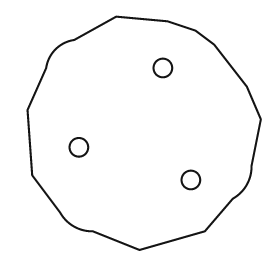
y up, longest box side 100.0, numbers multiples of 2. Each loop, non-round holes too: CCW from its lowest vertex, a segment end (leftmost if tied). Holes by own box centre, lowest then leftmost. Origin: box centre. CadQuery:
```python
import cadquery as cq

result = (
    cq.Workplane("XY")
    .moveTo(-2.0, -50.0)
    .lineTo(26.0, -42.0)
    .lineTo(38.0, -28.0)
    .threePointArc((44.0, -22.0), (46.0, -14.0))
    .lineTo(50.0, 6.0)
    .lineTo(44.0, 20.0)
    .lineTo(30.0, 38.0)
    .lineTo(22.0, 44.0)
    .lineTo(10.0, 48.0)
    .lineTo(-12.0, 50.0)
    .lineTo(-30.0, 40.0)
    .threePointArc((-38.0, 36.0), (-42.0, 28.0))
    .lineTo(-50.0, 10.0)
    .lineTo(-48.0, -18.0)
    .lineTo(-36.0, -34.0)
    .threePointArc((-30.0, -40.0), (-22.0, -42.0))
    .close()
    .moveTo(20.0, -20.0)
    .circle(4.0)
    .moveTo(-28.0, -6.0)
    .circle(4.0)
    .moveTo(8.0, 28.0)
    .circle(4.0)
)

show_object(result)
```